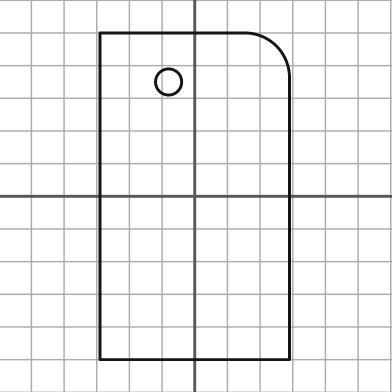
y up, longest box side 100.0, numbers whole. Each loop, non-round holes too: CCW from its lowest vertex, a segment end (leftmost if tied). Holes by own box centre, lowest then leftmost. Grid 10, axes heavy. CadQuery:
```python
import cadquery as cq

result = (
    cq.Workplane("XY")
    .moveTo(-29.0, -50.0)
    .lineTo(29.0, -50.0)
    .lineTo(29.0, 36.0)
    .threePointArc((25.0, 46.0), (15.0, 50.0))
    .lineTo(-29.0, 50.0)
    .close()
    .moveTo(-8.0, 35.0)
    .circle(4.0)
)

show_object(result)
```